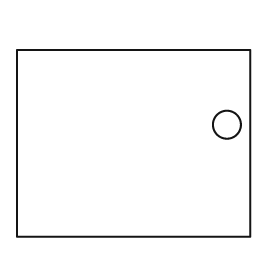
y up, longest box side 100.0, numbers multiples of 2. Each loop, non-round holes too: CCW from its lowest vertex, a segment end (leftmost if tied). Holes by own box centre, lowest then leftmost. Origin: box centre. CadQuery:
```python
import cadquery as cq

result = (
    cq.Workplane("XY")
    .moveTo(-50.0, -40.0)
    .lineTo(50.0, -40.0)
    .lineTo(50.0, 40.0)
    .lineTo(-50.0, 40.0)
    .close()
    .moveTo(40.0, 8.0)
    .circle(6.0)
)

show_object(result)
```